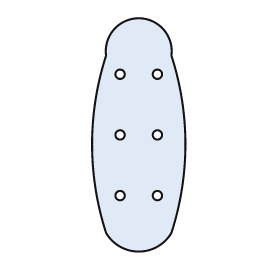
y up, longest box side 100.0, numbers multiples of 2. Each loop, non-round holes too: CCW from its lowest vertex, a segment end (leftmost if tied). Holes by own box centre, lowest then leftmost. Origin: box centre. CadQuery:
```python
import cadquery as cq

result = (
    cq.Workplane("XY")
    .moveTo(-14.0, -42.0)
    .threePointArc((0.0, -50.0), (14.0, -42.0))
    .threePointArc((20.0, -4.0), (14.0, 34.0))
    .threePointArc((0.0, 50.0), (-14.0, 34.0))
    .threePointArc((-20.0, -4.0), (-14.0, -42.0))
    .close()
    .moveTo(-8.0, -26.0)
    .circle(2.0)
    .moveTo(8.0, -26.0)
    .circle(2.0)
    .moveTo(-8.0, 0.0)
    .circle(2.0)
    .moveTo(8.0, 0.0)
    .circle(2.0)
    .moveTo(-8.0, 26.0)
    .circle(2.0)
    .moveTo(8.0, 26.0)
    .circle(2.0)
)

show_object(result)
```